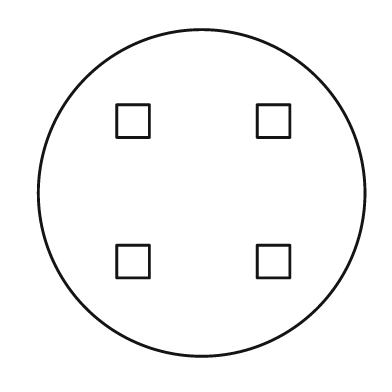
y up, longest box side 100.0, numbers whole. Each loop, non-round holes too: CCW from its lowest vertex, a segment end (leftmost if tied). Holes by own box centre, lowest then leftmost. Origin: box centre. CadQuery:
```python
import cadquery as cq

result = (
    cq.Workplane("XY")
    .moveTo(0.0, 0.0)
    .circle(50.0)
    .moveTo(-26.0, -26.0)
    .lineTo(-16.0, -26.0)
    .lineTo(-16.0, -16.0)
    .lineTo(-26.0, -16.0)
    .close()
    .moveTo(17.0, -26.0)
    .lineTo(27.0, -26.0)
    .lineTo(27.0, -16.0)
    .lineTo(17.0, -16.0)
    .close()
    .moveTo(-26.0, 17.0)
    .lineTo(-16.0, 17.0)
    .lineTo(-16.0, 27.0)
    .lineTo(-26.0, 27.0)
    .close()
    .moveTo(17.0, 17.0)
    .lineTo(27.0, 17.0)
    .lineTo(27.0, 27.0)
    .lineTo(17.0, 27.0)
    .close()
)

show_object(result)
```